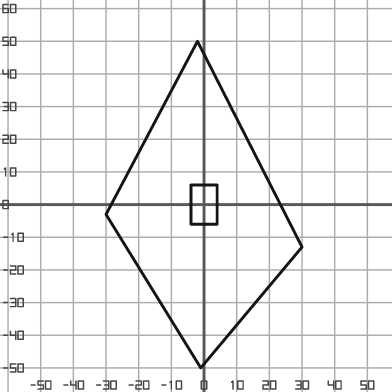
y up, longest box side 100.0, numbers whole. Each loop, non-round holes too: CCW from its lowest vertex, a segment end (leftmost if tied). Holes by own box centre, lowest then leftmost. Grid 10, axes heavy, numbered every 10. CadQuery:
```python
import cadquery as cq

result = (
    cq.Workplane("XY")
    .moveTo(-1.0, -50.0)
    .lineTo(30.0, -13.0)
    .lineTo(-2.0, 50.0)
    .lineTo(-30.0, -3.0)
    .close()
    .moveTo(-4.0, -6.0)
    .lineTo(4.0, -6.0)
    .lineTo(4.0, 6.0)
    .lineTo(-4.0, 6.0)
    .close()
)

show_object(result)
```